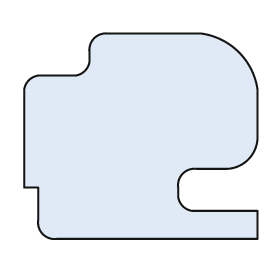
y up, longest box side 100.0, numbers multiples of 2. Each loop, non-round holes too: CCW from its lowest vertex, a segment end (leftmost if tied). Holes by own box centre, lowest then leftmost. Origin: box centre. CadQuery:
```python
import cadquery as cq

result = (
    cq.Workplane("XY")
    .moveTo(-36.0, -44.0)
    .lineTo(50.0, -44.0)
    .lineTo(50.0, -32.0)
    .lineTo(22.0, -32.0)
    .threePointArc((18.0, -30.0), (16.0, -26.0))
    .lineTo(16.0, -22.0)
    .threePointArc((18.0, -16.0), (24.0, -14.0))
    .lineTo(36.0, -14.0)
    .threePointArc((46.0, -10.0), (50.0, 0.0))
    .lineTo(50.0, 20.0)
    .threePointArc((42.0, 36.0), (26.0, 44.0))
    .lineTo(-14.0, 44.0)
    .threePointArc((-20.0, 42.0), (-22.0, 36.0))
    .lineTo(-22.0, 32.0)
    .threePointArc((-24.0, 28.0), (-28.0, 26.0))
    .lineTo(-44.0, 26.0)
    .threePointArc((-48.0, 24.0), (-50.0, 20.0))
    .lineTo(-50.0, -22.0)
    .lineTo(-44.0, -22.0)
    .lineTo(-44.0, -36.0)
    .threePointArc((-42.0, -42.0), (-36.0, -44.0))
    .close()
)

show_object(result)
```